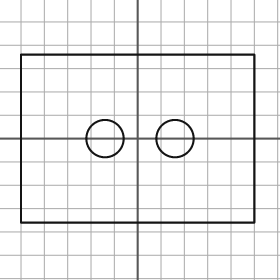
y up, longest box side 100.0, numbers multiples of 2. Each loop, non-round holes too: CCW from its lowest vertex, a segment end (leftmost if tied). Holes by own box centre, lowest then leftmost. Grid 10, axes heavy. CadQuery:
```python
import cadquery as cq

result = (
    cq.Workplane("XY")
    .moveTo(-50.0, -36.0)
    .lineTo(50.0, -36.0)
    .lineTo(50.0, 36.0)
    .lineTo(-50.0, 36.0)
    .close()
    .moveTo(-14.0, 0.0)
    .circle(8.0)
    .moveTo(16.0, 0.0)
    .circle(8.0)
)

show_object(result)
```